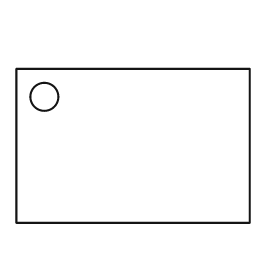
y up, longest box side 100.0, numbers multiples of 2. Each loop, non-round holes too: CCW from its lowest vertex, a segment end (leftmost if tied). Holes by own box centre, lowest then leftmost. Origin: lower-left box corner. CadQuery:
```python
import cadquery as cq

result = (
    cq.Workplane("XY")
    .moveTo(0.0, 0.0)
    .lineTo(100.0, 0.0)
    .lineTo(100.0, 66.0)
    .lineTo(0.0, 66.0)
    .close()
    .moveTo(12.0, 54.0)
    .circle(6.0)
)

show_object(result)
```